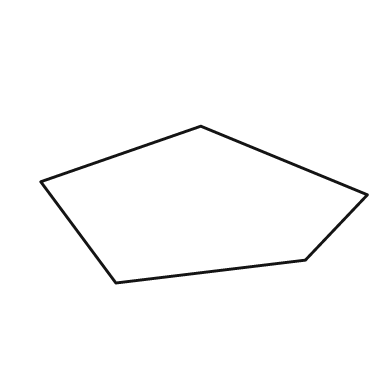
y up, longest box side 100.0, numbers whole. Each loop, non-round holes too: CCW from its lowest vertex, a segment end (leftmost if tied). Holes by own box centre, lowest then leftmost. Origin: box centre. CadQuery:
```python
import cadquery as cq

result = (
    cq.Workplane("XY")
    .moveTo(-27.0, -24.0)
    .lineTo(31.0, -17.0)
    .lineTo(50.0, 3.0)
    .lineTo(-1.0, 24.0)
    .lineTo(-50.0, 7.0)
    .close()
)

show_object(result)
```